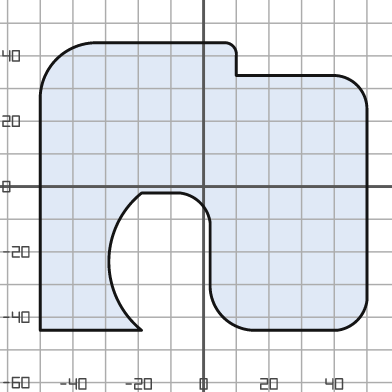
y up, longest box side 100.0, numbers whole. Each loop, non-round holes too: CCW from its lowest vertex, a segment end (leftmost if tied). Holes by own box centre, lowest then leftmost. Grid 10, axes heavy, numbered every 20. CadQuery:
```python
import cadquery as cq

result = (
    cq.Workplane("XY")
    .moveTo(-50.0, -44.0)
    .lineTo(-19.0, -44.0)
    .threePointArc((-29.0, -23.0), (-19.0, -2.0))
    .lineTo(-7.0, -2.0)
    .threePointArc((-1.0, -5.0), (2.0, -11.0))
    .lineTo(2.0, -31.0)
    .threePointArc((6.0, -40.0), (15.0, -44.0))
    .lineTo(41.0, -44.0)
    .threePointArc((47.0, -41.0), (50.0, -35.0))
    .lineTo(50.0, 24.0)
    .threePointArc((47.0, 31.0), (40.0, 34.0))
    .lineTo(10.0, 34.0)
    .lineTo(10.0, 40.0)
    .threePointArc((9.0, 43.0), (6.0, 44.0))
    .lineTo(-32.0, 44.0)
    .threePointArc((-45.0, 39.0), (-50.0, 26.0))
    .close()
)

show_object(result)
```